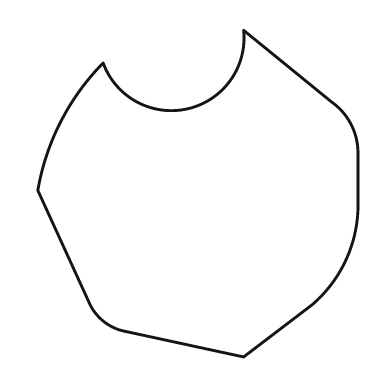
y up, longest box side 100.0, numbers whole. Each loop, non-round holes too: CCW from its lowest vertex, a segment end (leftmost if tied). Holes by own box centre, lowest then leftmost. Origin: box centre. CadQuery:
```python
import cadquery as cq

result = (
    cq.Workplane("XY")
    .moveTo(14.0, -50.0)
    .lineTo(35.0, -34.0)
    .threePointArc((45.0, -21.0), (49.0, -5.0))
    .lineTo(49.0, 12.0)
    .threePointArc((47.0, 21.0), (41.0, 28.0))
    .lineTo(14.0, 50.0)
    .threePointArc((-3.0, 26.0), (-29.0, 40.0))
    .threePointArc((-42.0, 22.0), (-49.0, 1.0))
    .lineTo(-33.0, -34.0)
    .threePointArc((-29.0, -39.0), (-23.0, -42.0))
    .close()
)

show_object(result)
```